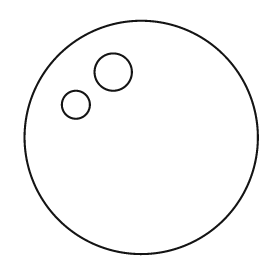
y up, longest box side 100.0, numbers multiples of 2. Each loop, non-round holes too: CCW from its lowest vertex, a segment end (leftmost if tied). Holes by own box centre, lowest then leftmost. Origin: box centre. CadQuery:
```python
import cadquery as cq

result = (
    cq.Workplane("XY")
    .moveTo(0.0, 0.0)
    .circle(50.0)
    .moveTo(-28.0, 14.0)
    .circle(6.0)
    .moveTo(-12.0, 28.0)
    .circle(8.0)
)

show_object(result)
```